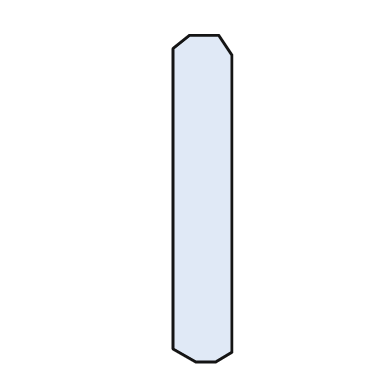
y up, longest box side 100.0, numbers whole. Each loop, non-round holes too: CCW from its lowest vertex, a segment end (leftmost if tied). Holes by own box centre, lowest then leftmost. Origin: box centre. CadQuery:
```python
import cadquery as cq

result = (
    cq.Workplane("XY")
    .moveTo(-2.0, -50.0)
    .lineTo(4.0, -50.0)
    .lineTo(9.0, -47.0)
    .lineTo(9.0, 44.0)
    .lineTo(5.0, 50.0)
    .lineTo(-4.0, 50.0)
    .lineTo(-9.0, 46.0)
    .lineTo(-9.0, -46.0)
    .close()
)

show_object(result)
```